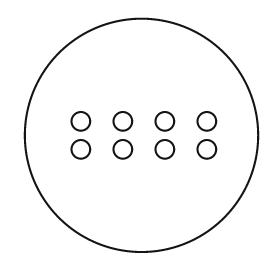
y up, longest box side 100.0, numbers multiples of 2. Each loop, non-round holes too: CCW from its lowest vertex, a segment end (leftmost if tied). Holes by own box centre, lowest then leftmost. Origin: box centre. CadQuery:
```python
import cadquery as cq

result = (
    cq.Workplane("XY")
    .moveTo(0.0, 0.0)
    .circle(50.0)
    .moveTo(-26.0, -6.0)
    .circle(4.0)
    .moveTo(-8.0, -6.0)
    .circle(4.0)
    .moveTo(10.0, -6.0)
    .circle(4.0)
    .moveTo(28.0, -6.0)
    .circle(4.0)
    .moveTo(-26.0, 6.0)
    .circle(4.0)
    .moveTo(-8.0, 6.0)
    .circle(4.0)
    .moveTo(10.0, 6.0)
    .circle(4.0)
    .moveTo(28.0, 6.0)
    .circle(4.0)
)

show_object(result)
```